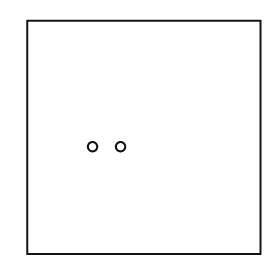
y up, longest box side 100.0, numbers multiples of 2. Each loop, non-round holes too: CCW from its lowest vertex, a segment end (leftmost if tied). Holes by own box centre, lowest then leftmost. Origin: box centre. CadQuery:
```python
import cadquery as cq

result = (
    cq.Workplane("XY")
    .moveTo(-50.0, -50.0)
    .lineTo(50.0, -50.0)
    .lineTo(50.0, 50.0)
    .lineTo(-50.0, 50.0)
    .close()
    .moveTo(-22.0, -4.0)
    .circle(2.0)
    .moveTo(-10.0, -4.0)
    .circle(2.0)
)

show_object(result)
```